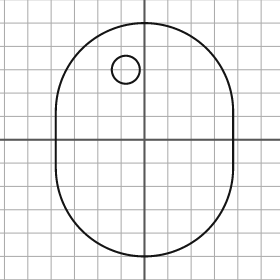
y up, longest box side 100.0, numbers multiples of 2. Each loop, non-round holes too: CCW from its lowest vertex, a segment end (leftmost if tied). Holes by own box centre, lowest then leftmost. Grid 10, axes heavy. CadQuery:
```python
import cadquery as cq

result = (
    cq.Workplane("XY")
    .moveTo(-38.0, -12.0)
    .threePointArc((0.0, -50.0), (38.0, -12.0))
    .lineTo(38.0, 12.0)
    .threePointArc((0.0, 50.0), (-38.0, 12.0))
    .close()
    .moveTo(-8.0, 30.0)
    .circle(6.0)
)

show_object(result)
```